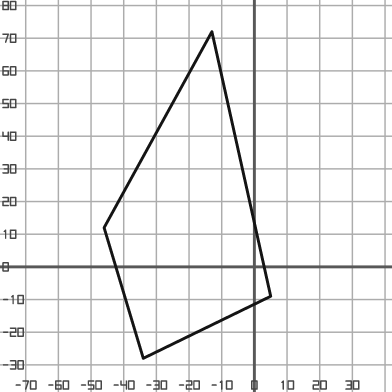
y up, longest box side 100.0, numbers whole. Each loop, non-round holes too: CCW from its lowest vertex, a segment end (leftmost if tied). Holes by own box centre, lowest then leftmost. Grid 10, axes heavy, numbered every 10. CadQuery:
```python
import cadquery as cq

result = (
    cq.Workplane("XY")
    .moveTo(-34.0, -28.0)
    .lineTo(5.0, -9.0)
    .lineTo(-13.0, 72.0)
    .lineTo(-46.0, 12.0)
    .close()
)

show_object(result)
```